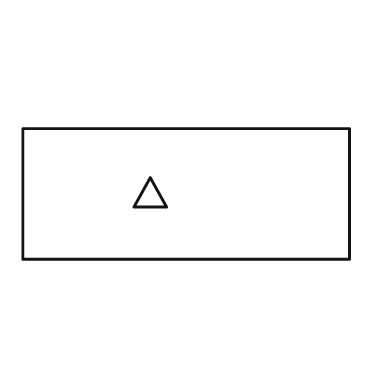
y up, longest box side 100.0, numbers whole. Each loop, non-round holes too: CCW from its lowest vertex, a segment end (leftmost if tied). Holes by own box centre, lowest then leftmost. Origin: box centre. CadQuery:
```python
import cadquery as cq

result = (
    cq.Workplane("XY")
    .moveTo(-50.0, -20.0)
    .lineTo(50.0, -20.0)
    .lineTo(50.0, 20.0)
    .lineTo(-50.0, 20.0)
    .close()
    .moveTo(-16.0, -4.0)
    .lineTo(-6.0, -4.0)
    .lineTo(-11.0, 5.0)
    .close()
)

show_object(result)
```